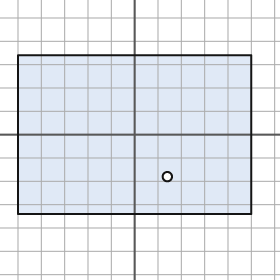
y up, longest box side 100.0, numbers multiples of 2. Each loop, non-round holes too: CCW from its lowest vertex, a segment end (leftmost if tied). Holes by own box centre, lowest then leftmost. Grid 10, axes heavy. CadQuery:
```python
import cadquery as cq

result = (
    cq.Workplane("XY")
    .moveTo(-50.0, -34.0)
    .lineTo(50.0, -34.0)
    .lineTo(50.0, 34.0)
    .lineTo(-50.0, 34.0)
    .close()
    .moveTo(14.0, -18.0)
    .circle(2.0)
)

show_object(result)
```